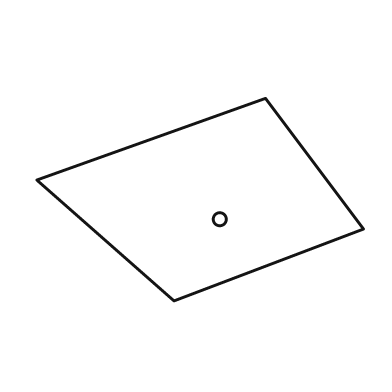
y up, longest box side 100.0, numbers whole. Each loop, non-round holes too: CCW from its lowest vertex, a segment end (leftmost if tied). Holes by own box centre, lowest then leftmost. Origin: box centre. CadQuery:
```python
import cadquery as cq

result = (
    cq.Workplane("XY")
    .moveTo(-8.0, -31.0)
    .lineTo(50.0, -9.0)
    .lineTo(20.0, 31.0)
    .lineTo(-50.0, 6.0)
    .close()
    .moveTo(6.0, -6.0)
    .circle(2.0)
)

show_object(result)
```